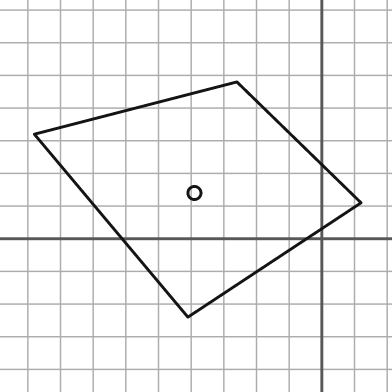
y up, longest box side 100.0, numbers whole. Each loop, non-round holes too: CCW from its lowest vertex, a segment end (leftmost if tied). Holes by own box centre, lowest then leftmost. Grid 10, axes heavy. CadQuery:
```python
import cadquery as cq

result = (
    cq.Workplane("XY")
    .moveTo(-41.0, -24.0)
    .lineTo(12.0, 11.0)
    .lineTo(-26.0, 48.0)
    .lineTo(-88.0, 32.0)
    .close()
    .moveTo(-39.0, 14.0)
    .circle(2.0)
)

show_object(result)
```